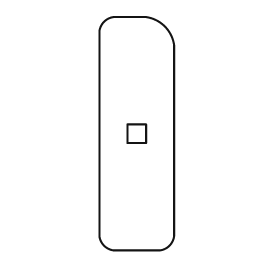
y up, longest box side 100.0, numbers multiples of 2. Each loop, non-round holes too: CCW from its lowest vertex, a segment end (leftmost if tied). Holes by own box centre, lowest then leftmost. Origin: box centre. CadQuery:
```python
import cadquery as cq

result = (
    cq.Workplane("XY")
    .moveTo(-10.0, -50.0)
    .lineTo(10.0, -50.0)
    .threePointArc((14.0, -48.0), (16.0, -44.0))
    .lineTo(16.0, 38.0)
    .threePointArc((12.0, 46.0), (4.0, 50.0))
    .lineTo(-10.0, 50.0)
    .threePointArc((-14.0, 48.0), (-16.0, 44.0))
    .lineTo(-16.0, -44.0)
    .threePointArc((-14.0, -48.0), (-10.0, -50.0))
    .close()
    .moveTo(-4.0, -4.0)
    .lineTo(4.0, -4.0)
    .lineTo(4.0, 4.0)
    .lineTo(-4.0, 4.0)
    .close()
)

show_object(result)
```